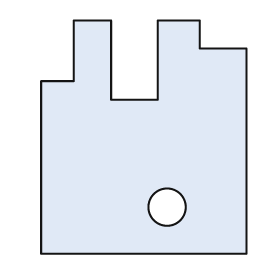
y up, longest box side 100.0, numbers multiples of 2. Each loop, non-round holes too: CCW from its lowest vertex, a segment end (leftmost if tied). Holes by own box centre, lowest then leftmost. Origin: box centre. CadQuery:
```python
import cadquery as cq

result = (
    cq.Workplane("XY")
    .moveTo(-44.0, -50.0)
    .lineTo(44.0, -50.0)
    .lineTo(44.0, 38.0)
    .lineTo(24.0, 38.0)
    .lineTo(24.0, 50.0)
    .lineTo(6.0, 50.0)
    .lineTo(6.0, 16.0)
    .lineTo(-14.0, 16.0)
    .lineTo(-14.0, 50.0)
    .lineTo(-30.0, 50.0)
    .lineTo(-30.0, 24.0)
    .lineTo(-44.0, 24.0)
    .close()
    .moveTo(10.0, -30.0)
    .circle(8.0)
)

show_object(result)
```